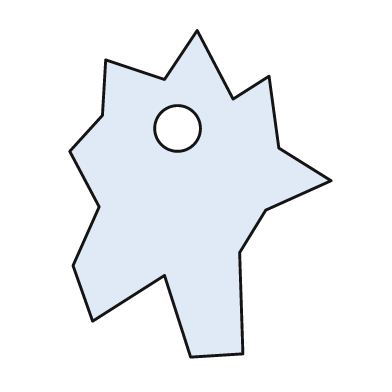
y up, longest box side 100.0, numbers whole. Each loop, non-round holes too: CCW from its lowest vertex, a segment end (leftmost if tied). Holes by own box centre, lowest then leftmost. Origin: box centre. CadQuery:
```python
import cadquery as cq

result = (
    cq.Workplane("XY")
    .moveTo(-3.0, -50.0)
    .lineTo(13.0, -49.0)
    .lineTo(12.0, -18.0)
    .lineTo(20.0, -5.0)
    .lineTo(40.0, 4.0)
    .lineTo(24.0, 14.0)
    .lineTo(21.0, 36.0)
    .lineTo(10.0, 29.0)
    .lineTo(-1.0, 50.0)
    .lineTo(-11.0, 35.0)
    .lineTo(-29.0, 41.0)
    .lineTo(-30.0, 24.0)
    .lineTo(-40.0, 13.0)
    .lineTo(-31.0, -4.0)
    .lineTo(-39.0, -22.0)
    .lineTo(-33.0, -39.0)
    .lineTo(-11.0, -25.0)
    .close()
    .moveTo(-7.0, 20.0)
    .circle(7.0)
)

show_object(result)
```